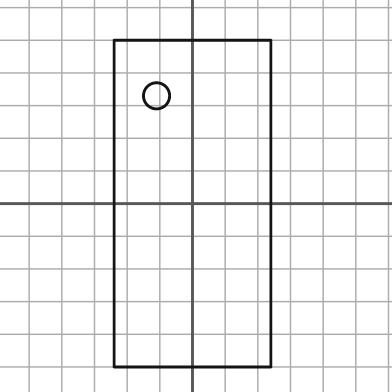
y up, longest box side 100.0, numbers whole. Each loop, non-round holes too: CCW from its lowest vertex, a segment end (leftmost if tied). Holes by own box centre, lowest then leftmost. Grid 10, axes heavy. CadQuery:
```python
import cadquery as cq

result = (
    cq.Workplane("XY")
    .moveTo(-24.0, -50.0)
    .lineTo(24.0, -50.0)
    .lineTo(24.0, 50.0)
    .lineTo(-24.0, 50.0)
    .close()
    .moveTo(-11.0, 33.0)
    .circle(4.0)
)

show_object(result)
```